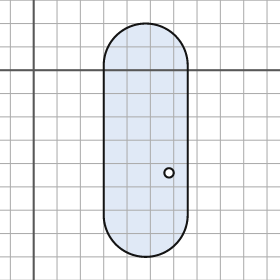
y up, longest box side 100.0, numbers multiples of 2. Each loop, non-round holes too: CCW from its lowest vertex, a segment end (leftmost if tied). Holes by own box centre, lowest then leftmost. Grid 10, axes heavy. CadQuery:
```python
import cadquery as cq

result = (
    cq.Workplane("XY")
    .moveTo(30.0, -62.0)
    .threePointArc((48.0, -80.0), (66.0, -62.0))
    .lineTo(66.0, 2.0)
    .threePointArc((48.0, 20.0), (30.0, 2.0))
    .close()
    .moveTo(58.0, -44.0)
    .circle(2.0)
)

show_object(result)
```